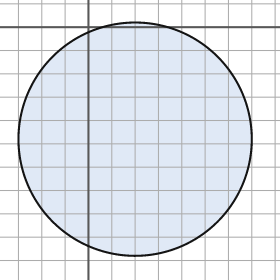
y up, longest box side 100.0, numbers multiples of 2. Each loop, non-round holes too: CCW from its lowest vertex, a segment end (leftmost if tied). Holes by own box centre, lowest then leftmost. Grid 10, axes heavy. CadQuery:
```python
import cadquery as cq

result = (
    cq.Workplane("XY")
    .moveTo(20.0, -48.0)
    .circle(50.0)
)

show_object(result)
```